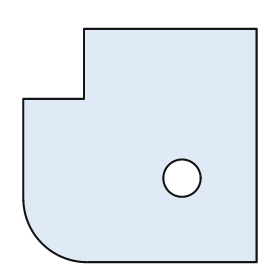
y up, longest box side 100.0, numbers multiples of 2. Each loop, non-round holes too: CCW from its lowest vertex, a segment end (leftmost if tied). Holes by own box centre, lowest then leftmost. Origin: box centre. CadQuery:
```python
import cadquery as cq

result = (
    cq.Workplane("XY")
    .moveTo(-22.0, -50.0)
    .lineTo(50.0, -50.0)
    .lineTo(50.0, 50.0)
    .lineTo(-24.0, 50.0)
    .lineTo(-24.0, 20.0)
    .lineTo(-50.0, 20.0)
    .lineTo(-50.0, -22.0)
    .threePointArc((-42.0, -42.0), (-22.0, -50.0))
    .close()
    .moveTo(18.0, -14.0)
    .circle(8.0)
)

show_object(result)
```